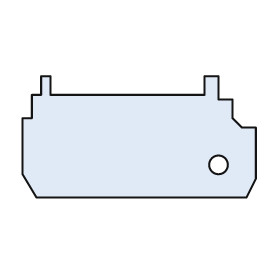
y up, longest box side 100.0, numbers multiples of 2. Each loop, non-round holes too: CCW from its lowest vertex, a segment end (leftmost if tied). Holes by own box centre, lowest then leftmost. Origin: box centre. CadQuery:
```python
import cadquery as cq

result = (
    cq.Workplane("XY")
    .moveTo(-44.0, -26.0)
    .lineTo(46.0, -26.0)
    .lineTo(50.0, -18.0)
    .lineTo(50.0, 4.0)
    .lineTo(44.0, 4.0)
    .lineTo(40.0, 8.0)
    .lineTo(40.0, 16.0)
    .lineTo(34.0, 16.0)
    .lineTo(34.0, 26.0)
    .lineTo(28.0, 26.0)
    .lineTo(28.0, 18.0)
    .lineTo(-38.0, 18.0)
    .lineTo(-38.0, 26.0)
    .lineTo(-42.0, 26.0)
    .lineTo(-42.0, 18.0)
    .lineTo(-46.0, 18.0)
    .lineTo(-46.0, 8.0)
    .lineTo(-50.0, 8.0)
    .lineTo(-50.0, -16.0)
    .close()
    .moveTo(34.0, -12.0)
    .circle(4.0)
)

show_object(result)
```